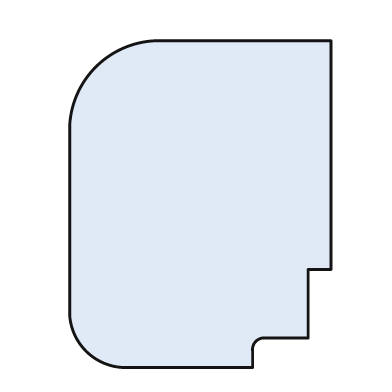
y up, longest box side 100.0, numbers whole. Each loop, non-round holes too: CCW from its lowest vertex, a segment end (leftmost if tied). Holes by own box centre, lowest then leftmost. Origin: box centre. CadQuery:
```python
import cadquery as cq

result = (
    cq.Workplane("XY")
    .moveTo(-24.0, -50.0)
    .lineTo(16.0, -50.0)
    .lineTo(16.0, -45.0)
    .threePointArc((17.0, -42.0), (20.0, -41.0))
    .lineTo(33.0, -41.0)
    .lineTo(33.0, -20.0)
    .lineTo(40.0, -20.0)
    .lineTo(40.0, 50.0)
    .lineTo(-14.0, 50.0)
    .threePointArc((-32.0, 42.0), (-40.0, 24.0))
    .lineTo(-40.0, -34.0)
    .threePointArc((-35.0, -45.0), (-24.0, -50.0))
    .close()
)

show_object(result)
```